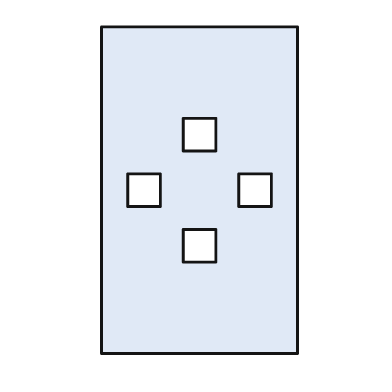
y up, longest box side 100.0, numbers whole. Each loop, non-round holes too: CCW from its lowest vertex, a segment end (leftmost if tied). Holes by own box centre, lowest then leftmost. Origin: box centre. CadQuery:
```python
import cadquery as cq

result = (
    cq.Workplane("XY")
    .moveTo(-30.0, -50.0)
    .lineTo(30.0, -50.0)
    .lineTo(30.0, 50.0)
    .lineTo(-30.0, 50.0)
    .close()
    .moveTo(-5.0, -22.0)
    .lineTo(5.0, -22.0)
    .lineTo(5.0, -12.0)
    .lineTo(-5.0, -12.0)
    .close()
    .moveTo(-22.0, -5.0)
    .lineTo(-12.0, -5.0)
    .lineTo(-12.0, 5.0)
    .lineTo(-22.0, 5.0)
    .close()
    .moveTo(12.0, -5.0)
    .lineTo(22.0, -5.0)
    .lineTo(22.0, 5.0)
    .lineTo(12.0, 5.0)
    .close()
    .moveTo(-5.0, 12.0)
    .lineTo(5.0, 12.0)
    .lineTo(5.0, 22.0)
    .lineTo(-5.0, 22.0)
    .close()
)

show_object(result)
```